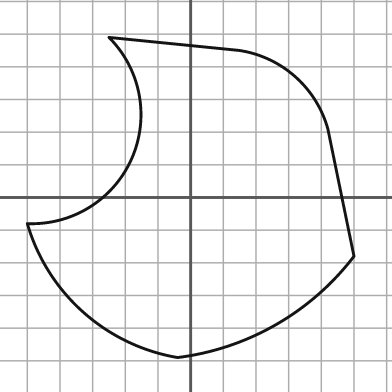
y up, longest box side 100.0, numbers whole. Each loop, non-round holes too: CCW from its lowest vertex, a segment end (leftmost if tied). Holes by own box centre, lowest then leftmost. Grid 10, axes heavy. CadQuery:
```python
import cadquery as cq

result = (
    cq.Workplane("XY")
    .moveTo(-4.0, -49.0)
    .threePointArc((26.0, -39.0), (50.0, -18.0))
    .lineTo(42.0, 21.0)
    .threePointArc((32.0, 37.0), (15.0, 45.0))
    .lineTo(-25.0, 49.0)
    .threePointArc((-18.0, 12.0), (-50.0, -8.0))
    .threePointArc((-33.0, -35.0), (-4.0, -49.0))
    .close()
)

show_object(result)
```